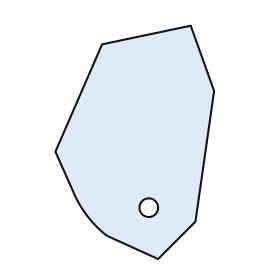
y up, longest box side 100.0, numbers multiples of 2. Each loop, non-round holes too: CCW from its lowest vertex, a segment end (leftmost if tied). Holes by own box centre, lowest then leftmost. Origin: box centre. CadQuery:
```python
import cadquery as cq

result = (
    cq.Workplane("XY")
    .moveTo(10.0, -50.0)
    .lineTo(26.0, -34.0)
    .lineTo(34.0, 22.0)
    .lineTo(24.0, 50.0)
    .lineTo(-14.0, 42.0)
    .lineTo(-34.0, -4.0)
    .lineTo(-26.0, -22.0)
    .threePointArc((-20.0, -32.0), (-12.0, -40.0))
    .close()
    .moveTo(6.0, -28.0)
    .circle(4.0)
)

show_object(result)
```